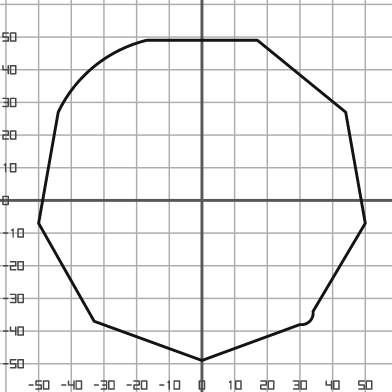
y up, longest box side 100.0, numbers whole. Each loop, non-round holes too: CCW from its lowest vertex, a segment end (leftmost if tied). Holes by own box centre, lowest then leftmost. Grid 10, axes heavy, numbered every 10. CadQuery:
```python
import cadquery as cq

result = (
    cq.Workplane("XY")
    .moveTo(0.0, -49.0)
    .lineTo(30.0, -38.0)
    .threePointArc((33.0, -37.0), (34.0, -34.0))
    .lineTo(50.0, -7.0)
    .lineTo(44.0, 27.0)
    .lineTo(17.0, 49.0)
    .lineTo(-17.0, 49.0)
    .threePointArc((-33.0, 41.0), (-44.0, 27.0))
    .lineTo(-50.0, -7.0)
    .lineTo(-33.0, -37.0)
    .close()
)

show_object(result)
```